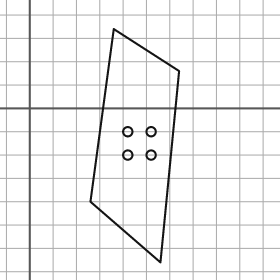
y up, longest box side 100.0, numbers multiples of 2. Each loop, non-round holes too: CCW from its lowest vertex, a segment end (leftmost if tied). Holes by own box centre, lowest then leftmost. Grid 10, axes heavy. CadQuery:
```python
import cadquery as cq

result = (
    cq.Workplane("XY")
    .moveTo(56.0, -66.0)
    .lineTo(64.0, 16.0)
    .lineTo(36.0, 34.0)
    .lineTo(26.0, -40.0)
    .close()
    .moveTo(42.0, -20.0)
    .circle(2.0)
    .moveTo(52.0, -20.0)
    .circle(2.0)
    .moveTo(42.0, -10.0)
    .circle(2.0)
    .moveTo(52.0, -10.0)
    .circle(2.0)
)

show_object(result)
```